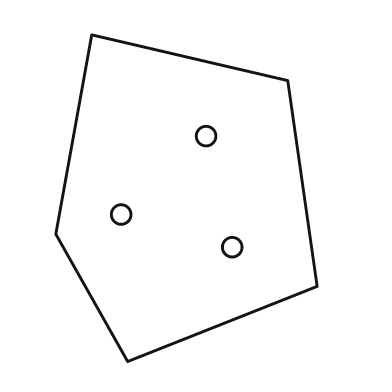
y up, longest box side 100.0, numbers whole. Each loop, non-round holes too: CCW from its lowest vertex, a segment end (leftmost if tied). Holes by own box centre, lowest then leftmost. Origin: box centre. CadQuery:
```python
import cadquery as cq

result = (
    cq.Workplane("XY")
    .moveTo(-18.0, -50.0)
    .lineTo(40.0, -27.0)
    .lineTo(31.0, 36.0)
    .lineTo(-29.0, 50.0)
    .lineTo(-40.0, -11.0)
    .close()
    .moveTo(14.0, -15.0)
    .circle(3.0)
    .moveTo(-20.0, -5.0)
    .circle(3.0)
    .moveTo(6.0, 19.0)
    .circle(3.0)
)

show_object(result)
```